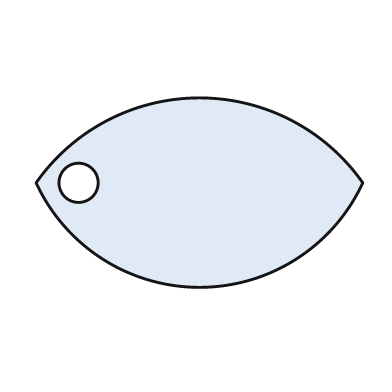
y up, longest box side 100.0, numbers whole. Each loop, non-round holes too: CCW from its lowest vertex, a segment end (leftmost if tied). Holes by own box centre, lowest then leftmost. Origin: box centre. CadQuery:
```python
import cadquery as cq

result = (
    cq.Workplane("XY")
    .moveTo(-50.0, 3.0)
    .threePointArc((0.0, -29.0), (50.0, 3.0))
    .threePointArc((0.0, 29.0), (-50.0, 3.0))
    .close()
    .moveTo(-37.0, 3.0)
    .circle(6.0)
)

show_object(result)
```